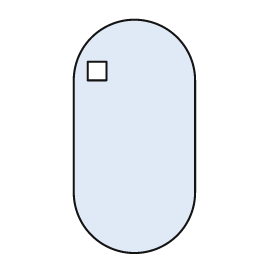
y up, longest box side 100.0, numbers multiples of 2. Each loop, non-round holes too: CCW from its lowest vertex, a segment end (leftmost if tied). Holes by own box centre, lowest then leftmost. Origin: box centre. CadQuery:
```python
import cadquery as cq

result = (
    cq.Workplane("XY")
    .moveTo(-26.0, -24.0)
    .threePointArc((0.0, -50.0), (26.0, -24.0))
    .lineTo(26.0, 24.0)
    .threePointArc((0.0, 50.0), (-26.0, 24.0))
    .close()
    .moveTo(-20.0, 24.0)
    .lineTo(-12.0, 24.0)
    .lineTo(-12.0, 32.0)
    .lineTo(-20.0, 32.0)
    .close()
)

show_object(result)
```